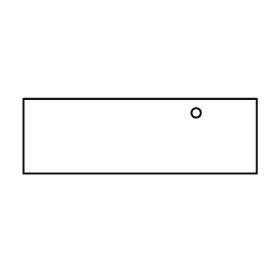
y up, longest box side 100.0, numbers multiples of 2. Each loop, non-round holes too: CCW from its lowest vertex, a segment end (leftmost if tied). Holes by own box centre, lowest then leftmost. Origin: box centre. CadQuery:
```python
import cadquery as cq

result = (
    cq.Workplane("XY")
    .moveTo(-50.0, -16.0)
    .lineTo(50.0, -16.0)
    .lineTo(50.0, 16.0)
    .lineTo(-50.0, 16.0)
    .close()
    .moveTo(24.0, 10.0)
    .circle(2.0)
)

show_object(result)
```